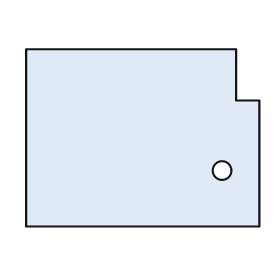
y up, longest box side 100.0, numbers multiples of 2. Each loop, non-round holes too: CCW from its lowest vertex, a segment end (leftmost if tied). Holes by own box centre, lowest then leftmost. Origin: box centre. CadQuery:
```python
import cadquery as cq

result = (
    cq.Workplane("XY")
    .moveTo(-50.0, -38.0)
    .lineTo(50.0, -38.0)
    .lineTo(50.0, 16.0)
    .lineTo(40.0, 16.0)
    .lineTo(40.0, 38.0)
    .lineTo(-50.0, 38.0)
    .close()
    .moveTo(34.0, -14.0)
    .circle(4.0)
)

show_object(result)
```